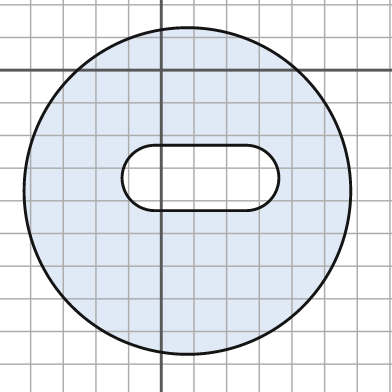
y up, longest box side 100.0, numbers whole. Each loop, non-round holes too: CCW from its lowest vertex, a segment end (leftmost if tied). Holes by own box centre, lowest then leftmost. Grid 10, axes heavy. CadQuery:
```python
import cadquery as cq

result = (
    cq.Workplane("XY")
    .moveTo(8.0, -37.0)
    .circle(50.0)
    .moveTo(-2.0, -43.0)
    .lineTo(26.0, -43.0)
    .threePointArc((36.0, -33.0), (26.0, -23.0))
    .lineTo(-2.0, -23.0)
    .threePointArc((-12.0, -33.0), (-2.0, -43.0))
    .close()
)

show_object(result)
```